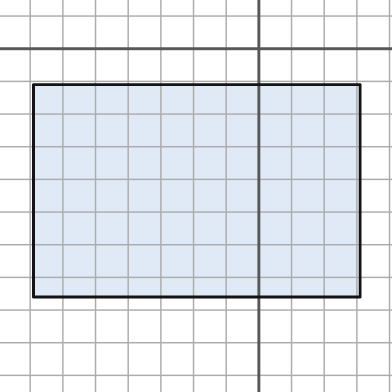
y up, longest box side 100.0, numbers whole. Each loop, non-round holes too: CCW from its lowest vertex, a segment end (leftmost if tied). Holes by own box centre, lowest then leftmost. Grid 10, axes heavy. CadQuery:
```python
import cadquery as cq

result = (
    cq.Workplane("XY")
    .moveTo(-69.0, -76.0)
    .lineTo(31.0, -76.0)
    .lineTo(31.0, -11.0)
    .lineTo(-69.0, -11.0)
    .close()
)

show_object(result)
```